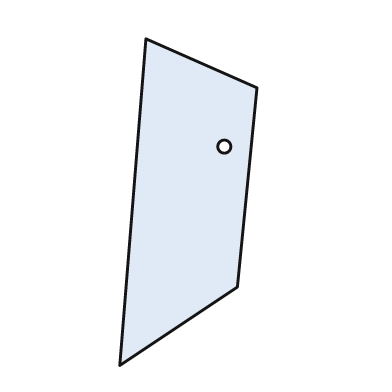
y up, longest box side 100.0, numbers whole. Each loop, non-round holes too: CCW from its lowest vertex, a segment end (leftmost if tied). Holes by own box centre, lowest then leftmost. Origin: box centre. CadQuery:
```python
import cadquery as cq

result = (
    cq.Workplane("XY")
    .moveTo(-21.0, -50.0)
    .lineTo(15.0, -26.0)
    .lineTo(21.0, 35.0)
    .lineTo(-13.0, 50.0)
    .close()
    .moveTo(11.0, 17.0)
    .circle(2.0)
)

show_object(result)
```